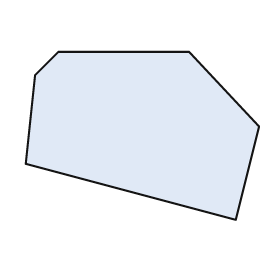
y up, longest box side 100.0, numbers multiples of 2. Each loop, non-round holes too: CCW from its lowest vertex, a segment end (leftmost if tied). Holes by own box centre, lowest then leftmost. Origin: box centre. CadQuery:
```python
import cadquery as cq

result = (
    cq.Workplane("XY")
    .moveTo(40.0, -36.0)
    .lineTo(50.0, 4.0)
    .lineTo(20.0, 36.0)
    .lineTo(-36.0, 36.0)
    .lineTo(-46.0, 26.0)
    .lineTo(-50.0, -12.0)
    .close()
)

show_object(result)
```